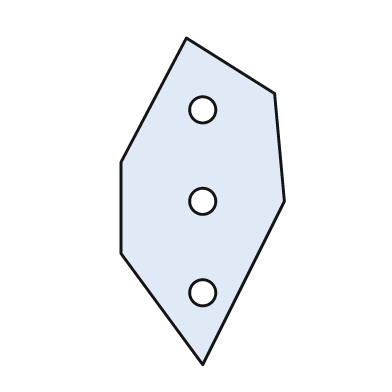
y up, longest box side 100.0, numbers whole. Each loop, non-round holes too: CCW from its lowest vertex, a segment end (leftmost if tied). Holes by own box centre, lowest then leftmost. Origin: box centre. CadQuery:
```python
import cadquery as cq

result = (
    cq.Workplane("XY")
    .moveTo(0.0, -50.0)
    .lineTo(25.0, 0.0)
    .lineTo(22.0, 33.0)
    .lineTo(-5.0, 50.0)
    .lineTo(-25.0, 12.0)
    .lineTo(-25.0, -16.0)
    .close()
    .moveTo(0.0, -28.0)
    .circle(4.0)
    .moveTo(0.0, 0.0)
    .circle(4.0)
    .moveTo(0.0, 28.0)
    .circle(4.0)
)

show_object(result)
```